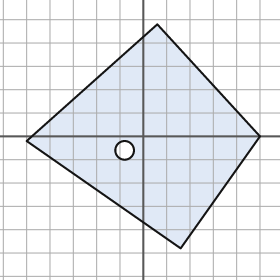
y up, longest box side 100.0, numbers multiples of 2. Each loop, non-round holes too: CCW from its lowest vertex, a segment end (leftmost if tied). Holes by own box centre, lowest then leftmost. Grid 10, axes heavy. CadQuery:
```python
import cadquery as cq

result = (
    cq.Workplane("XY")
    .moveTo(16.0, -48.0)
    .lineTo(50.0, 0.0)
    .lineTo(6.0, 48.0)
    .lineTo(-50.0, -2.0)
    .close()
    .moveTo(-8.0, -6.0)
    .circle(4.0)
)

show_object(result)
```